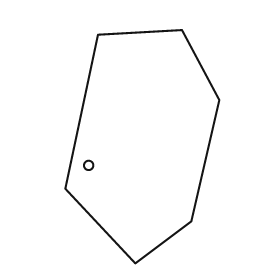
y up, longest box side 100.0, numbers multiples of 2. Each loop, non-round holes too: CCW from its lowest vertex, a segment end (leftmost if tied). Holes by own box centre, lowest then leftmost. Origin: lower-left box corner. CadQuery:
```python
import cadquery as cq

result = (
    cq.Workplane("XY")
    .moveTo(30.0, 0.0)
    .lineTo(54.0, 18.0)
    .lineTo(66.0, 70.0)
    .lineTo(50.0, 100.0)
    .lineTo(14.0, 98.0)
    .lineTo(0.0, 32.0)
    .close()
    .moveTo(10.0, 42.0)
    .circle(2.0)
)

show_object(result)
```